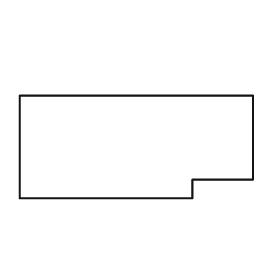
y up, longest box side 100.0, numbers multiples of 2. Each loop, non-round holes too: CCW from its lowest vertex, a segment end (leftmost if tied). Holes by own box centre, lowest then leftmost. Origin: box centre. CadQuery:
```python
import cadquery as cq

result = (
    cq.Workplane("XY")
    .moveTo(-50.0, -22.0)
    .lineTo(24.0, -22.0)
    .lineTo(24.0, -14.0)
    .lineTo(50.0, -14.0)
    .lineTo(50.0, 22.0)
    .lineTo(-50.0, 22.0)
    .close()
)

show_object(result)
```